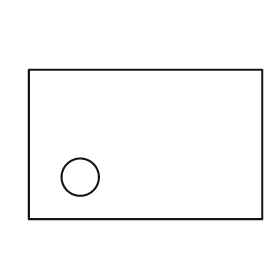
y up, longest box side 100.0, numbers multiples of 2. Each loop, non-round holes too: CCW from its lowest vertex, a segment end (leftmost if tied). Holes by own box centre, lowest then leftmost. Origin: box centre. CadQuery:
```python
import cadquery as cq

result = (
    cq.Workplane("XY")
    .moveTo(-50.0, -32.0)
    .lineTo(50.0, -32.0)
    .lineTo(50.0, 32.0)
    .lineTo(-50.0, 32.0)
    .close()
    .moveTo(-28.0, -14.0)
    .circle(8.0)
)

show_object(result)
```